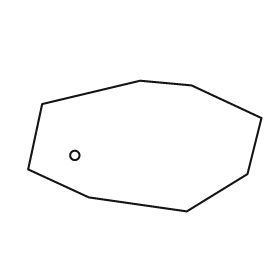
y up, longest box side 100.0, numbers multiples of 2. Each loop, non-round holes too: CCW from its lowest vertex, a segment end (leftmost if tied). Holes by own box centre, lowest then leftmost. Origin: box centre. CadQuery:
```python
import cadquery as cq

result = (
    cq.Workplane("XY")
    .moveTo(18.0, -28.0)
    .lineTo(44.0, -12.0)
    .lineTo(50.0, 12.0)
    .lineTo(20.0, 26.0)
    .lineTo(-2.0, 28.0)
    .lineTo(-44.0, 18.0)
    .lineTo(-50.0, -10.0)
    .lineTo(-24.0, -22.0)
    .close()
    .moveTo(-30.0, -4.0)
    .circle(2.0)
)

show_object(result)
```